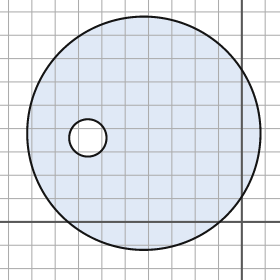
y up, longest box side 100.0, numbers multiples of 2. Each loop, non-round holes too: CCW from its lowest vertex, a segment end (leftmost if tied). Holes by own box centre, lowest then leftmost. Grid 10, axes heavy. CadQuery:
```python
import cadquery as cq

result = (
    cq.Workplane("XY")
    .moveTo(-42.0, 38.0)
    .circle(50.0)
    .moveTo(-66.0, 36.0)
    .circle(8.0)
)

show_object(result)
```